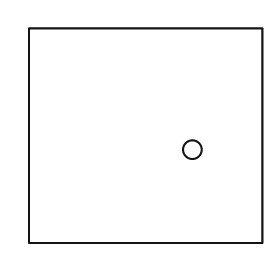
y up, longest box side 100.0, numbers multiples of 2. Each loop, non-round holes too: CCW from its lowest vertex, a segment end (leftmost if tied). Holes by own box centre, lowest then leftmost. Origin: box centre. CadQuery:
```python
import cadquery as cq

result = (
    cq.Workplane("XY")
    .moveTo(-50.0, -46.0)
    .lineTo(50.0, -46.0)
    .lineTo(50.0, 46.0)
    .lineTo(-50.0, 46.0)
    .close()
    .moveTo(20.0, -6.0)
    .circle(4.0)
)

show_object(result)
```